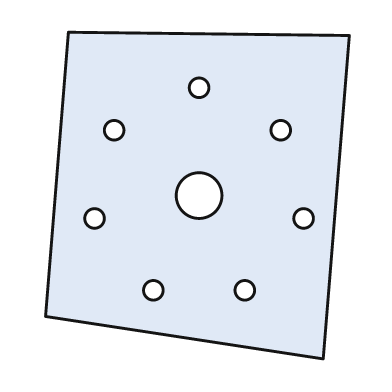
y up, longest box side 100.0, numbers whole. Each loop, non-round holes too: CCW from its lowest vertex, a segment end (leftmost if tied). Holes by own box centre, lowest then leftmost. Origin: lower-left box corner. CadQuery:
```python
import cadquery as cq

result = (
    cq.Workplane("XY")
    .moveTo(85.0, 0.0)
    .lineTo(93.0, 99.0)
    .lineTo(7.0, 100.0)
    .lineTo(0.0, 13.0)
    .close()
    .moveTo(33.0, 21.0)
    .circle(3.0)
    .moveTo(61.0, 21.0)
    .circle(3.0)
    .moveTo(15.0, 43.0)
    .circle(3.0)
    .moveTo(79.0, 43.0)
    .circle(3.0)
    .moveTo(47.0, 50.0)
    .circle(7.0)
    .moveTo(21.0, 70.0)
    .circle(3.0)
    .moveTo(72.0, 70.0)
    .circle(3.0)
    .moveTo(47.0, 83.0)
    .circle(3.0)
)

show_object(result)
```